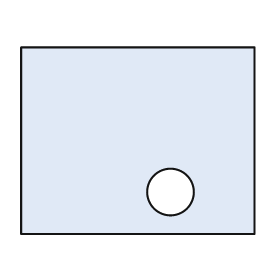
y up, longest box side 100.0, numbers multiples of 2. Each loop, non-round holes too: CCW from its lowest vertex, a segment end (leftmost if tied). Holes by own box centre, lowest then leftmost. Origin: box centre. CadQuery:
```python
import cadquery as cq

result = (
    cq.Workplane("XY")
    .moveTo(-50.0, -40.0)
    .lineTo(50.0, -40.0)
    .lineTo(50.0, 40.0)
    .lineTo(-50.0, 40.0)
    .close()
    .moveTo(14.0, -22.0)
    .circle(10.0)
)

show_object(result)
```